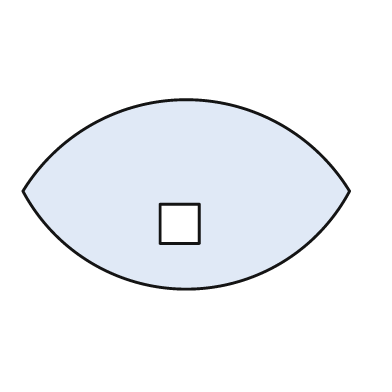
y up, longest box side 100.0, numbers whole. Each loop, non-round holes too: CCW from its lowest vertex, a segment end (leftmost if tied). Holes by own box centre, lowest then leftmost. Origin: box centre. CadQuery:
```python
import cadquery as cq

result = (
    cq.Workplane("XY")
    .moveTo(-50.0, 1.0)
    .threePointArc((0.0, -29.0), (50.0, 1.0))
    .threePointArc((0.0, 29.0), (-50.0, 1.0))
    .close()
    .moveTo(-8.0, -15.0)
    .lineTo(4.0, -15.0)
    .lineTo(4.0, -3.0)
    .lineTo(-8.0, -3.0)
    .close()
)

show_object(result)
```